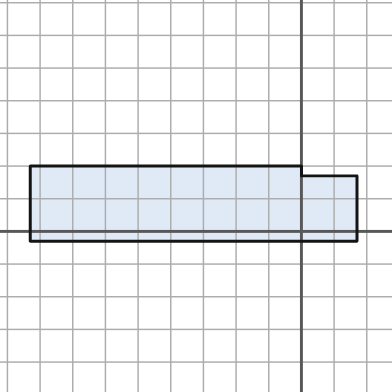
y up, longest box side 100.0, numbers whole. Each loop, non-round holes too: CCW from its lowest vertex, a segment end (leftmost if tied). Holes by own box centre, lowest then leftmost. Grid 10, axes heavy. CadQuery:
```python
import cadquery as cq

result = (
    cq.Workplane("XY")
    .moveTo(-83.0, -3.0)
    .lineTo(17.0, -3.0)
    .lineTo(17.0, 17.0)
    .lineTo(0.0, 17.0)
    .lineTo(0.0, 20.0)
    .lineTo(-83.0, 20.0)
    .close()
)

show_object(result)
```